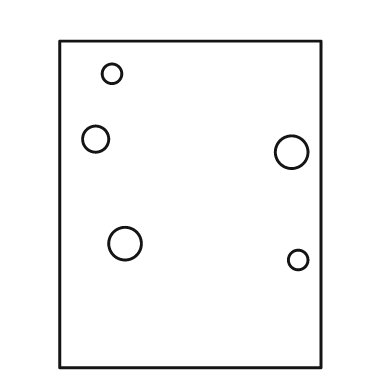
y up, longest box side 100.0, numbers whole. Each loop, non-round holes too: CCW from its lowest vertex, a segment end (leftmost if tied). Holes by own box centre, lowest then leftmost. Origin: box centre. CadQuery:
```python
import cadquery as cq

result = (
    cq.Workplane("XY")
    .moveTo(-40.0, -50.0)
    .lineTo(40.0, -50.0)
    .lineTo(40.0, 50.0)
    .lineTo(-40.0, 50.0)
    .close()
    .moveTo(33.0, -17.0)
    .circle(3.0)
    .moveTo(-20.0, -12.0)
    .circle(5.0)
    .moveTo(31.0, 16.0)
    .circle(5.0)
    .moveTo(-29.0, 20.0)
    .circle(4.0)
    .moveTo(-24.0, 40.0)
    .circle(3.0)
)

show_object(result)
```